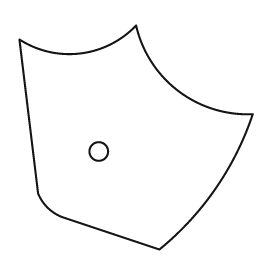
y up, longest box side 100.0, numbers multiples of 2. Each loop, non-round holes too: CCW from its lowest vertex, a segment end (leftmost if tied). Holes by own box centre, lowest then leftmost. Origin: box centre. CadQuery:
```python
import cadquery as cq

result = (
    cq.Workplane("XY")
    .moveTo(10.0, -48.0)
    .threePointArc((34.0, -22.0), (50.0, 10.0))
    .threePointArc((18.0, 20.0), (0.0, 48.0))
    .threePointArc((-24.0, 36.0), (-50.0, 42.0))
    .lineTo(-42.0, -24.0)
    .threePointArc((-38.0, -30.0), (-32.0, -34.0))
    .close()
    .moveTo(-16.0, -6.0)
    .circle(4.0)
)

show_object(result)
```